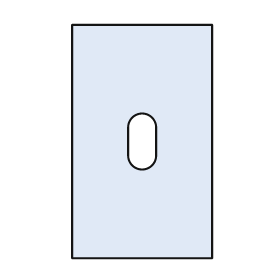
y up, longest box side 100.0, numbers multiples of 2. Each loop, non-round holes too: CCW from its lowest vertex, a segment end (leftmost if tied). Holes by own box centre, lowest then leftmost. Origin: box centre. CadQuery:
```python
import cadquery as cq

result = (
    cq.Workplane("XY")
    .moveTo(-30.0, -50.0)
    .lineTo(30.0, -50.0)
    .lineTo(30.0, 50.0)
    .lineTo(-30.0, 50.0)
    .close()
    .moveTo(-6.0, -6.0)
    .threePointArc((0.0, -12.0), (6.0, -6.0))
    .lineTo(6.0, 6.0)
    .threePointArc((0.0, 12.0), (-6.0, 6.0))
    .close()
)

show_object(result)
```